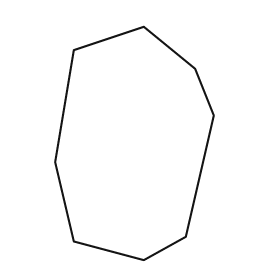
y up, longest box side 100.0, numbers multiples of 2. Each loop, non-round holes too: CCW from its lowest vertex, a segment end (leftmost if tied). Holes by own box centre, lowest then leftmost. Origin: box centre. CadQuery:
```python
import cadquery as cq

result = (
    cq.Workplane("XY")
    .moveTo(4.0, -50.0)
    .lineTo(22.0, -40.0)
    .lineTo(34.0, 12.0)
    .lineTo(26.0, 32.0)
    .lineTo(4.0, 50.0)
    .lineTo(-26.0, 40.0)
    .lineTo(-34.0, -8.0)
    .lineTo(-26.0, -42.0)
    .close()
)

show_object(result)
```